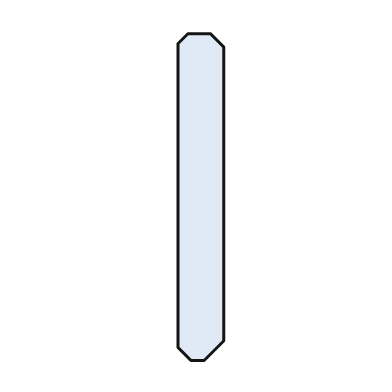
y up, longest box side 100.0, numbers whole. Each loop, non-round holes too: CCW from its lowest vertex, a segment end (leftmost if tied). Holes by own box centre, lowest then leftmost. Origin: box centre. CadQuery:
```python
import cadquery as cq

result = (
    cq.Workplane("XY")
    .moveTo(-3.0, -50.0)
    .lineTo(1.0, -50.0)
    .lineTo(7.0, -44.0)
    .lineTo(7.0, 46.0)
    .lineTo(3.0, 50.0)
    .lineTo(-4.0, 50.0)
    .lineTo(-7.0, 47.0)
    .lineTo(-7.0, -46.0)
    .close()
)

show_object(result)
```